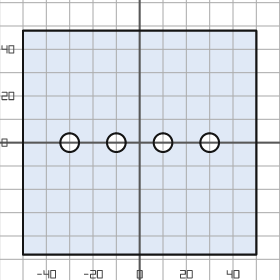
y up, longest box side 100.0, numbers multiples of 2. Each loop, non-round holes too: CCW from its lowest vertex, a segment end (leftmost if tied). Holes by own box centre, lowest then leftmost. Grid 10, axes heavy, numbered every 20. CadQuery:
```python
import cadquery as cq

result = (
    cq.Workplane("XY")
    .moveTo(-50.0, -48.0)
    .lineTo(50.0, -48.0)
    .lineTo(50.0, 48.0)
    .lineTo(-50.0, 48.0)
    .close()
    .moveTo(-30.0, 0.0)
    .circle(4.0)
    .moveTo(-10.0, 0.0)
    .circle(4.0)
    .moveTo(10.0, 0.0)
    .circle(4.0)
    .moveTo(30.0, 0.0)
    .circle(4.0)
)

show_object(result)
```